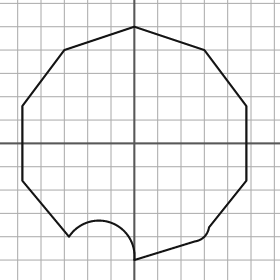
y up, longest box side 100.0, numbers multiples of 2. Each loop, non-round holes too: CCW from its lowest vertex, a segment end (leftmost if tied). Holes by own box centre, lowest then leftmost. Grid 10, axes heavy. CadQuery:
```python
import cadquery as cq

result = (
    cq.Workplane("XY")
    .moveTo(0.0, -50.0)
    .lineTo(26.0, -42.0)
    .threePointArc((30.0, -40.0), (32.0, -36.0))
    .lineTo(48.0, -16.0)
    .lineTo(48.0, 16.0)
    .lineTo(30.0, 40.0)
    .lineTo(0.0, 50.0)
    .lineTo(-30.0, 40.0)
    .lineTo(-48.0, 16.0)
    .lineTo(-48.0, -16.0)
    .lineTo(-28.0, -40.0)
    .threePointArc((-10.0, -34.0), (0.0, -50.0))
    .close()
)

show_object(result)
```